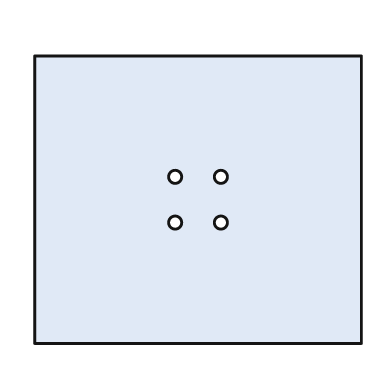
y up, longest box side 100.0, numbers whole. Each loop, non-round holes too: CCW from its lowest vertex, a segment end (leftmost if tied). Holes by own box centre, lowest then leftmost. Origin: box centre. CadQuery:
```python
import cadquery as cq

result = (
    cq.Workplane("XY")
    .moveTo(-50.0, -44.0)
    .lineTo(50.0, -44.0)
    .lineTo(50.0, 44.0)
    .lineTo(-50.0, 44.0)
    .close()
    .moveTo(-7.0, -7.0)
    .circle(2.0)
    .moveTo(7.0, -7.0)
    .circle(2.0)
    .moveTo(-7.0, 7.0)
    .circle(2.0)
    .moveTo(7.0, 7.0)
    .circle(2.0)
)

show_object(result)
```